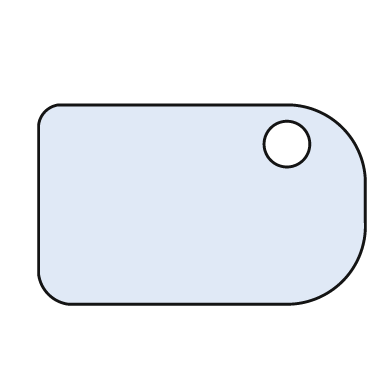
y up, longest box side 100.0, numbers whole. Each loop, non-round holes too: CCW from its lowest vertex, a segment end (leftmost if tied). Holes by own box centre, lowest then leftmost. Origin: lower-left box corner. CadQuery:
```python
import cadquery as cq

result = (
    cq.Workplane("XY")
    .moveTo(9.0, 0.0)
    .lineTo(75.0, 0.0)
    .threePointArc((93.0, 7.0), (100.0, 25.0))
    .lineTo(100.0, 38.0)
    .threePointArc((93.0, 54.0), (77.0, 61.0))
    .lineTo(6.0, 61.0)
    .threePointArc((2.0, 59.0), (0.0, 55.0))
    .lineTo(0.0, 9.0)
    .threePointArc((3.0, 3.0), (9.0, 0.0))
    .close()
    .moveTo(76.0, 49.0)
    .circle(7.0)
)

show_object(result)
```